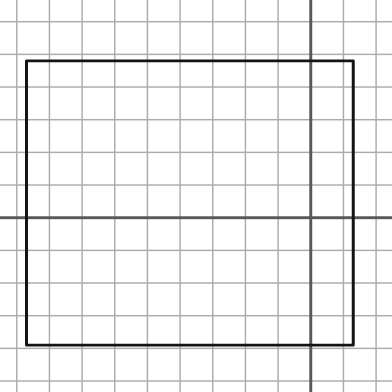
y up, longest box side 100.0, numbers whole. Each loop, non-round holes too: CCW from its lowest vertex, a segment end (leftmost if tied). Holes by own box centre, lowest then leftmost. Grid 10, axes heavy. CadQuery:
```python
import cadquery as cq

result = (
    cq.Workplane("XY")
    .moveTo(-87.0, -39.0)
    .lineTo(13.0, -39.0)
    .lineTo(13.0, 48.0)
    .lineTo(-87.0, 48.0)
    .close()
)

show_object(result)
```